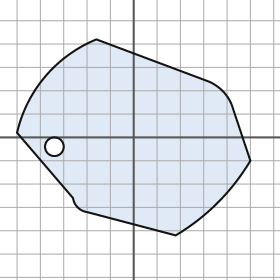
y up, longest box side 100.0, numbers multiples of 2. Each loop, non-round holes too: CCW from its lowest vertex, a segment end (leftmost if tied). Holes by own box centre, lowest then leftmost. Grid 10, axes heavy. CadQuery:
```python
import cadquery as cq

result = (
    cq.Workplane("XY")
    .moveTo(18.0, -42.0)
    .threePointArc((36.0, -28.0), (50.0, -10.0))
    .lineTo(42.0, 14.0)
    .threePointArc((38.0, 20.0), (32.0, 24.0))
    .lineTo(-16.0, 42.0)
    .threePointArc((-38.0, 26.0), (-50.0, 2.0))
    .lineTo(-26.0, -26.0)
    .threePointArc((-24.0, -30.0), (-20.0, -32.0))
    .close()
    .moveTo(-34.0, -4.0)
    .circle(4.0)
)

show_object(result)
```